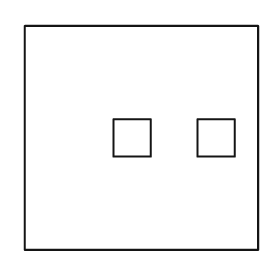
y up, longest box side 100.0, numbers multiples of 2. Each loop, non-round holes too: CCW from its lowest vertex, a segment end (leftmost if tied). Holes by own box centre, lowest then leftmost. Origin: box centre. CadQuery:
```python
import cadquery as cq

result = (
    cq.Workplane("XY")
    .moveTo(-50.0, -48.0)
    .lineTo(50.0, -48.0)
    .lineTo(50.0, 48.0)
    .lineTo(-50.0, 48.0)
    .close()
    .moveTo(-12.0, -8.0)
    .lineTo(4.0, -8.0)
    .lineTo(4.0, 8.0)
    .lineTo(-12.0, 8.0)
    .close()
    .moveTo(24.0, -8.0)
    .lineTo(40.0, -8.0)
    .lineTo(40.0, 8.0)
    .lineTo(24.0, 8.0)
    .close()
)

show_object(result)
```